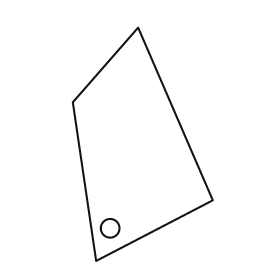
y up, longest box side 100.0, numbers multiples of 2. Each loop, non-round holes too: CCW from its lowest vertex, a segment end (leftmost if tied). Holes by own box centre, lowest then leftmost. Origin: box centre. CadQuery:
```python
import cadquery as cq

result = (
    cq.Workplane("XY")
    .moveTo(-20.0, -50.0)
    .lineTo(30.0, -24.0)
    .lineTo(-2.0, 50.0)
    .lineTo(-30.0, 18.0)
    .close()
    .moveTo(-14.0, -36.0)
    .circle(4.0)
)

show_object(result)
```